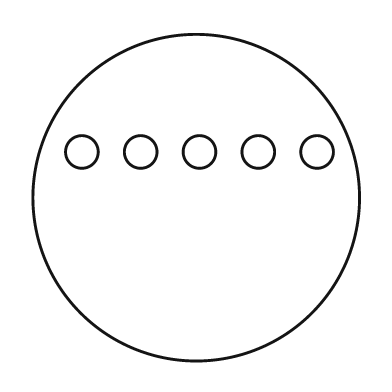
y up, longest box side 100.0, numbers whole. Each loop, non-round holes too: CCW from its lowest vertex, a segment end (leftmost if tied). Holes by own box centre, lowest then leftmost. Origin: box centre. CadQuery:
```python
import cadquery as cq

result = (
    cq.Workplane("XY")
    .moveTo(0.0, 0.0)
    .circle(50.0)
    .moveTo(-35.0, 14.0)
    .circle(5.0)
    .moveTo(-17.0, 14.0)
    .circle(5.0)
    .moveTo(1.0, 14.0)
    .circle(5.0)
    .moveTo(19.0, 14.0)
    .circle(5.0)
    .moveTo(37.0, 14.0)
    .circle(5.0)
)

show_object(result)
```